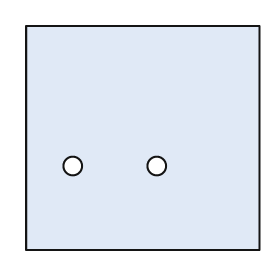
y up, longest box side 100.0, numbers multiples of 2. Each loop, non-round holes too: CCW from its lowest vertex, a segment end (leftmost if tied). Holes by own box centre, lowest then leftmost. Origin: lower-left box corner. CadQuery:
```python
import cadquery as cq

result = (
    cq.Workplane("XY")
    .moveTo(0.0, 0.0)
    .lineTo(100.0, 0.0)
    .lineTo(100.0, 96.0)
    .lineTo(0.0, 96.0)
    .close()
    .moveTo(20.0, 36.0)
    .circle(4.0)
    .moveTo(56.0, 36.0)
    .circle(4.0)
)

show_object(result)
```